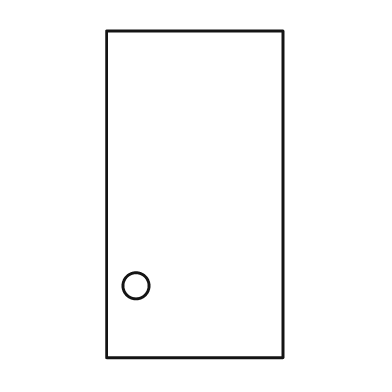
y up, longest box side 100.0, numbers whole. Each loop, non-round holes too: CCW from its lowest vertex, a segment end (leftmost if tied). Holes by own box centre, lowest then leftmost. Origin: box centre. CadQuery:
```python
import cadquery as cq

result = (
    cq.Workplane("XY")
    .moveTo(-27.0, -50.0)
    .lineTo(27.0, -50.0)
    .lineTo(27.0, 50.0)
    .lineTo(-27.0, 50.0)
    .close()
    .moveTo(-18.0, -28.0)
    .circle(4.0)
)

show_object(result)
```